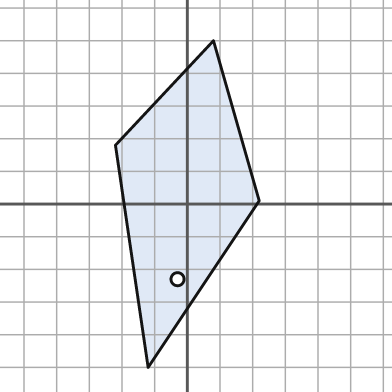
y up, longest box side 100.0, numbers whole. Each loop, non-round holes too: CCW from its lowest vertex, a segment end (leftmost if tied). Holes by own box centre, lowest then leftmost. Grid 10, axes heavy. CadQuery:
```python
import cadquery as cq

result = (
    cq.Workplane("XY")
    .moveTo(-12.0, -50.0)
    .lineTo(22.0, 1.0)
    .lineTo(8.0, 50.0)
    .lineTo(-22.0, 18.0)
    .close()
    .moveTo(-3.0, -23.0)
    .circle(2.0)
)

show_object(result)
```